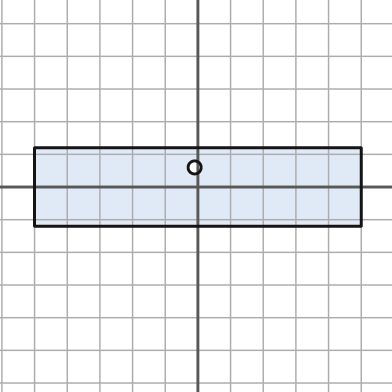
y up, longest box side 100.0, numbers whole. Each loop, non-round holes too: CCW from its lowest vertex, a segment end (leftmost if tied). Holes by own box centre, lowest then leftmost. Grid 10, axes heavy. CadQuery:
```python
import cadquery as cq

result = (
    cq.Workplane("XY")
    .moveTo(-50.0, -12.0)
    .lineTo(50.0, -12.0)
    .lineTo(50.0, 12.0)
    .lineTo(-50.0, 12.0)
    .close()
    .moveTo(-1.0, 6.0)
    .circle(2.0)
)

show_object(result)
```